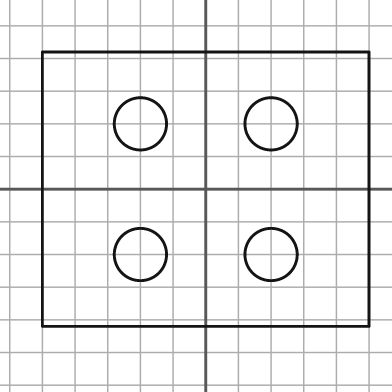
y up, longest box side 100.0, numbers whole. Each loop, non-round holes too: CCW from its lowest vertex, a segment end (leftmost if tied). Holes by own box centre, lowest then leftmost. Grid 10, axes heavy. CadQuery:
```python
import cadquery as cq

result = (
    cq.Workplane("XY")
    .moveTo(-50.0, -42.0)
    .lineTo(50.0, -42.0)
    .lineTo(50.0, 42.0)
    .lineTo(-50.0, 42.0)
    .close()
    .moveTo(-20.0, -20.0)
    .circle(8.0)
    .moveTo(20.0, -20.0)
    .circle(8.0)
    .moveTo(-20.0, 20.0)
    .circle(8.0)
    .moveTo(20.0, 20.0)
    .circle(8.0)
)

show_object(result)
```